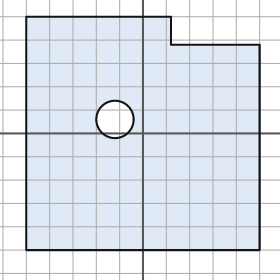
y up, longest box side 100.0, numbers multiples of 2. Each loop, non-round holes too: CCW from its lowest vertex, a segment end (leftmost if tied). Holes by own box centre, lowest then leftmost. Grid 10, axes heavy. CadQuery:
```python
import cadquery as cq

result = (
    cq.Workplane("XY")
    .moveTo(-50.0, -50.0)
    .lineTo(50.0, -50.0)
    .lineTo(50.0, 38.0)
    .lineTo(12.0, 38.0)
    .lineTo(12.0, 50.0)
    .lineTo(-50.0, 50.0)
    .close()
    .moveTo(-12.0, 6.0)
    .circle(8.0)
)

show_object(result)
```